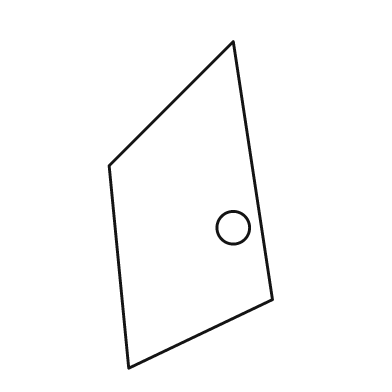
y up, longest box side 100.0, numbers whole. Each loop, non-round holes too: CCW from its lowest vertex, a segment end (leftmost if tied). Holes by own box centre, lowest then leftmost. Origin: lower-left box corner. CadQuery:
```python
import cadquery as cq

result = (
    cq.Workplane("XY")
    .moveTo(6.0, 0.0)
    .lineTo(50.0, 21.0)
    .lineTo(38.0, 100.0)
    .lineTo(0.0, 62.0)
    .close()
    .moveTo(38.0, 43.0)
    .circle(5.0)
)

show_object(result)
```